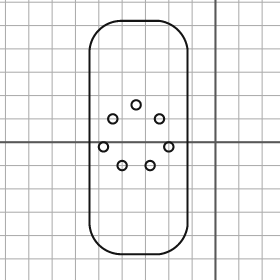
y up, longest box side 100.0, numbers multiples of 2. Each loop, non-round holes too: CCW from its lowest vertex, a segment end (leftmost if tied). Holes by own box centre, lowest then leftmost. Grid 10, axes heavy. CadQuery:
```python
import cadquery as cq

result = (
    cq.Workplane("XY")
    .moveTo(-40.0, -48.0)
    .lineTo(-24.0, -48.0)
    .threePointArc((-16.0, -44.0), (-12.0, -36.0))
    .lineTo(-12.0, 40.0)
    .threePointArc((-16.0, 48.0), (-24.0, 52.0))
    .lineTo(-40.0, 52.0)
    .threePointArc((-50.0, 48.0), (-54.0, 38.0))
    .lineTo(-54.0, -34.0)
    .threePointArc((-50.0, -44.0), (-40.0, -48.0))
    .close()
    .moveTo(-40.0, -10.0)
    .circle(2.0)
    .moveTo(-28.0, -10.0)
    .circle(2.0)
    .moveTo(-48.0, -2.0)
    .circle(2.0)
    .moveTo(-20.0, -2.0)
    .circle(2.0)
    .moveTo(-44.0, 10.0)
    .circle(2.0)
    .moveTo(-24.0, 10.0)
    .circle(2.0)
    .moveTo(-34.0, 16.0)
    .circle(2.0)
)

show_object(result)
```